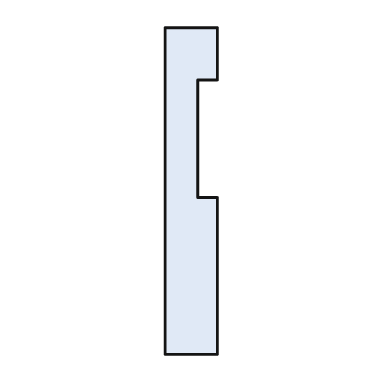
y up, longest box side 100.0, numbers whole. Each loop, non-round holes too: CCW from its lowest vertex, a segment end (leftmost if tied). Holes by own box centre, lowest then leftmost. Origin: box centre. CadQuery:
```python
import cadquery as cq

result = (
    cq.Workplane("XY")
    .moveTo(-8.0, -50.0)
    .lineTo(8.0, -50.0)
    .lineTo(8.0, -2.0)
    .lineTo(2.0, -2.0)
    .lineTo(2.0, 34.0)
    .lineTo(8.0, 34.0)
    .lineTo(8.0, 50.0)
    .lineTo(-8.0, 50.0)
    .close()
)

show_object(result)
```